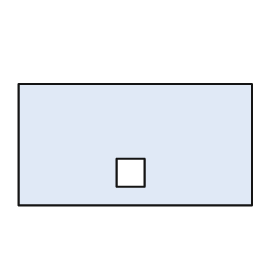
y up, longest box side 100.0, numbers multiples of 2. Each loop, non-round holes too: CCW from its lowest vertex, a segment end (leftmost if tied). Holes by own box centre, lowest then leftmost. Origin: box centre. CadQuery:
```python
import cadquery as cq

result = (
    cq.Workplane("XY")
    .moveTo(-50.0, -26.0)
    .lineTo(50.0, -26.0)
    .lineTo(50.0, 26.0)
    .lineTo(-50.0, 26.0)
    .close()
    .moveTo(-8.0, -18.0)
    .lineTo(4.0, -18.0)
    .lineTo(4.0, -6.0)
    .lineTo(-8.0, -6.0)
    .close()
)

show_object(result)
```